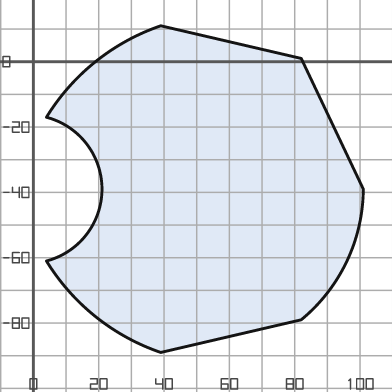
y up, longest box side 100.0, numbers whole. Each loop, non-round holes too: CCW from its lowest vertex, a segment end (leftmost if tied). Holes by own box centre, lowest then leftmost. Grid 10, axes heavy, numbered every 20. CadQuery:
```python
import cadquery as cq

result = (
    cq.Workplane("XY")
    .moveTo(39.0, -89.0)
    .lineTo(82.0, -79.0)
    .threePointArc((96.0, -61.0), (101.0, -39.0))
    .lineTo(82.0, 1.0)
    .lineTo(39.0, 11.0)
    .threePointArc((19.0, 0.0), (4.0, -17.0))
    .threePointArc((21.0, -39.0), (4.0, -61.0))
    .threePointArc((19.0, -78.0), (39.0, -89.0))
    .close()
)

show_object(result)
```